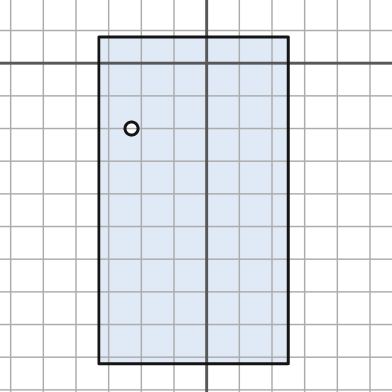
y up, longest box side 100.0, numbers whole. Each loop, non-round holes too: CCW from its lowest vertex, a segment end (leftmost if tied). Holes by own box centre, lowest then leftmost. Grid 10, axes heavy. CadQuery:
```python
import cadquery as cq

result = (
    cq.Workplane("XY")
    .moveTo(-33.0, -92.0)
    .lineTo(25.0, -92.0)
    .lineTo(25.0, 8.0)
    .lineTo(-33.0, 8.0)
    .close()
    .moveTo(-23.0, -20.0)
    .circle(2.0)
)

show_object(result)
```